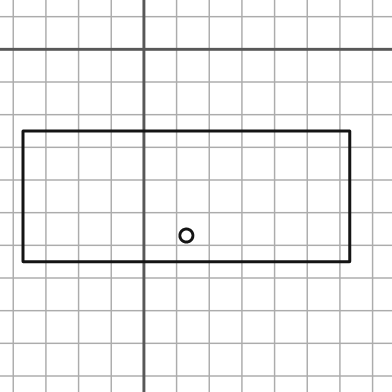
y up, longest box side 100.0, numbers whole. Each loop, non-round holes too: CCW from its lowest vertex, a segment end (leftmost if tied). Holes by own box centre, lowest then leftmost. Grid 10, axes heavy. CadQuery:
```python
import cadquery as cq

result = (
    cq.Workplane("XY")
    .moveTo(-37.0, -65.0)
    .lineTo(63.0, -65.0)
    .lineTo(63.0, -25.0)
    .lineTo(-37.0, -25.0)
    .close()
    .moveTo(13.0, -57.0)
    .circle(2.0)
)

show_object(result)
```